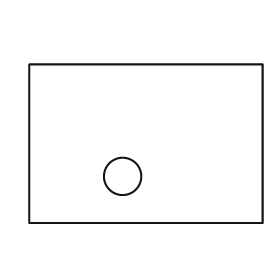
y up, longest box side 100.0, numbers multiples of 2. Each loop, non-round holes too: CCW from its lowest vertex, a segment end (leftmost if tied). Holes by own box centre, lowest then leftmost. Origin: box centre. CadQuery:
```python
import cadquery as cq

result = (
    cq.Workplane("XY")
    .moveTo(-50.0, -34.0)
    .lineTo(50.0, -34.0)
    .lineTo(50.0, 34.0)
    .lineTo(-50.0, 34.0)
    .close()
    .moveTo(-10.0, -14.0)
    .circle(8.0)
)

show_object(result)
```